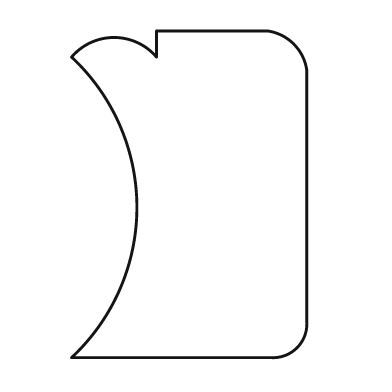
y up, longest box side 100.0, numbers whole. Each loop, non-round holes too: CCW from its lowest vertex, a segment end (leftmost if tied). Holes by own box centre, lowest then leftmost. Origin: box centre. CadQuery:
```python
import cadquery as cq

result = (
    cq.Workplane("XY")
    .moveTo(-36.0, -50.0)
    .lineTo(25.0, -50.0)
    .threePointArc((33.0, -47.0), (36.0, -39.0))
    .lineTo(36.0, 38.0)
    .threePointArc((32.0, 46.0), (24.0, 50.0))
    .lineTo(-10.0, 50.0)
    .lineTo(-10.0, 42.0)
    .threePointArc((-23.0, 48.0), (-36.0, 42.0))
    .threePointArc((-16.0, -4.0), (-36.0, -50.0))
    .close()
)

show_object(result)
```